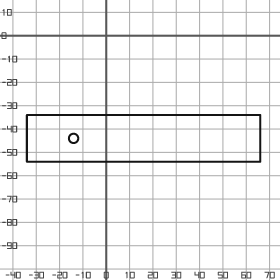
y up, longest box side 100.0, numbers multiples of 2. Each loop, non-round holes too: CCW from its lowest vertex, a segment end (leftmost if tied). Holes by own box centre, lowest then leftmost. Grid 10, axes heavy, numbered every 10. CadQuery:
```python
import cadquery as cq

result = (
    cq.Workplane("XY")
    .moveTo(-34.0, -54.0)
    .lineTo(66.0, -54.0)
    .lineTo(66.0, -34.0)
    .lineTo(-34.0, -34.0)
    .close()
    .moveTo(-14.0, -44.0)
    .circle(2.0)
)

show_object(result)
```